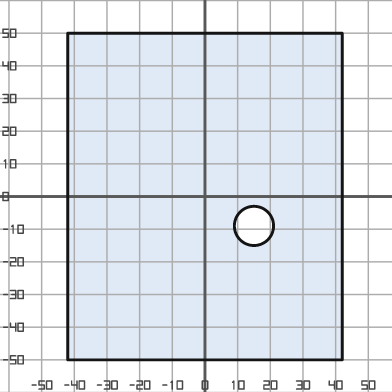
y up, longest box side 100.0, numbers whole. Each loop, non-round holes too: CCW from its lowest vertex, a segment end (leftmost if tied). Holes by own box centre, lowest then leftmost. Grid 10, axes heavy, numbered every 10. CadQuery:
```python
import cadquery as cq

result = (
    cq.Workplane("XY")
    .moveTo(-42.0, -50.0)
    .lineTo(42.0, -50.0)
    .lineTo(42.0, 50.0)
    .lineTo(-42.0, 50.0)
    .close()
    .moveTo(15.0, -9.0)
    .circle(6.0)
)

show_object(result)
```